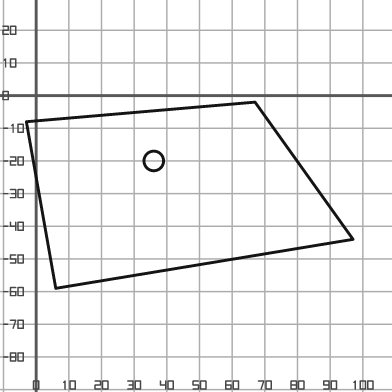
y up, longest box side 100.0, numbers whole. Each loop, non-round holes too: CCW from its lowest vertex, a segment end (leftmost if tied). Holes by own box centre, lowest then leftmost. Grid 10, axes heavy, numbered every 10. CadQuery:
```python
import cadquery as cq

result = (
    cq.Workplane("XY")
    .moveTo(6.0, -59.0)
    .lineTo(97.0, -44.0)
    .lineTo(67.0, -2.0)
    .lineTo(-3.0, -8.0)
    .close()
    .moveTo(36.0, -20.0)
    .circle(3.0)
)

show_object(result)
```